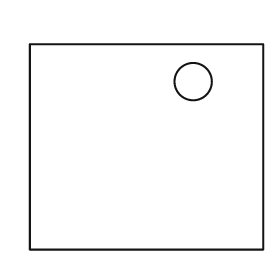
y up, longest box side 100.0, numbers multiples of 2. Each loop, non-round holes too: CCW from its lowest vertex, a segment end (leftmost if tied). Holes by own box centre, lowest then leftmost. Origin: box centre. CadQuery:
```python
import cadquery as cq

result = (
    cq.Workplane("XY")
    .moveTo(-50.0, -44.0)
    .lineTo(50.0, -44.0)
    .lineTo(50.0, 44.0)
    .lineTo(-50.0, 44.0)
    .close()
    .moveTo(20.0, 28.0)
    .circle(8.0)
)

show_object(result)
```